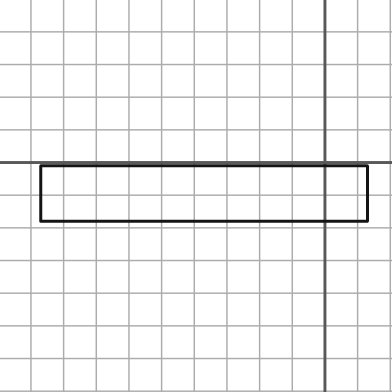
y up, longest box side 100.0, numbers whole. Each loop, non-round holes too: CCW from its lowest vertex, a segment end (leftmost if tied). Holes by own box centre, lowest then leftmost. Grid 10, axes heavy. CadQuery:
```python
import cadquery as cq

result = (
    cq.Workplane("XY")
    .moveTo(-87.0, -18.0)
    .lineTo(13.0, -18.0)
    .lineTo(13.0, -1.0)
    .lineTo(-87.0, -1.0)
    .close()
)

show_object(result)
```